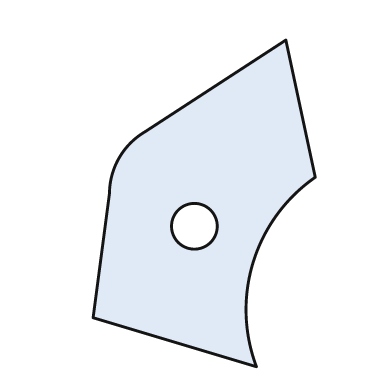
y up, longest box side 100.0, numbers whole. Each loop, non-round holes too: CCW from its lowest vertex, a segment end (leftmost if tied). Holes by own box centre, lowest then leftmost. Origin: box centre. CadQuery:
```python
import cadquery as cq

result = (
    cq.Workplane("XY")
    .moveTo(16.0, -50.0)
    .threePointArc((15.0, -18.0), (34.0, 8.0))
    .lineTo(25.0, 50.0)
    .lineTo(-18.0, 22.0)
    .threePointArc((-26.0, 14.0), (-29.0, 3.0))
    .lineTo(-34.0, -35.0)
    .close()
    .moveTo(-3.0, -7.0)
    .circle(7.0)
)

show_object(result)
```